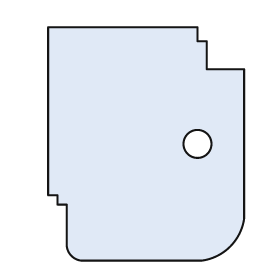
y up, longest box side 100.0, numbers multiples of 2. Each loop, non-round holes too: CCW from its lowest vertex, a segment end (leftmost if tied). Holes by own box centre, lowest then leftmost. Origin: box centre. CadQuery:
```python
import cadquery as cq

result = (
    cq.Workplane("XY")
    .moveTo(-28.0, -50.0)
    .lineTo(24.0, -50.0)
    .threePointArc((36.0, -44.0), (42.0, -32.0))
    .lineTo(42.0, 32.0)
    .lineTo(26.0, 32.0)
    .lineTo(26.0, 44.0)
    .lineTo(22.0, 44.0)
    .lineTo(22.0, 50.0)
    .lineTo(-42.0, 50.0)
    .lineTo(-42.0, -22.0)
    .lineTo(-38.0, -22.0)
    .lineTo(-38.0, -26.0)
    .lineTo(-34.0, -26.0)
    .lineTo(-34.0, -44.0)
    .threePointArc((-32.0, -48.0), (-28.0, -50.0))
    .close()
    .moveTo(22.0, 0.0)
    .circle(6.0)
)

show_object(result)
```